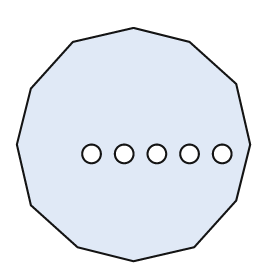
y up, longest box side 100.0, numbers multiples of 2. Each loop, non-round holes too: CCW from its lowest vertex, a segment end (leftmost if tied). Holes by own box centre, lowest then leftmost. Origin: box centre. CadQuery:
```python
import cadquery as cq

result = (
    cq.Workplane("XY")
    .moveTo(0.0, -50.0)
    .lineTo(26.0, -44.0)
    .lineTo(44.0, -24.0)
    .lineTo(50.0, 0.0)
    .lineTo(44.0, 26.0)
    .lineTo(24.0, 44.0)
    .lineTo(0.0, 50.0)
    .lineTo(-26.0, 44.0)
    .lineTo(-44.0, 24.0)
    .lineTo(-50.0, 0.0)
    .lineTo(-44.0, -26.0)
    .lineTo(-24.0, -44.0)
    .close()
    .moveTo(-18.0, -4.0)
    .circle(4.0)
    .moveTo(-4.0, -4.0)
    .circle(4.0)
    .moveTo(10.0, -4.0)
    .circle(4.0)
    .moveTo(24.0, -4.0)
    .circle(4.0)
    .moveTo(38.0, -4.0)
    .circle(4.0)
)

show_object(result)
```